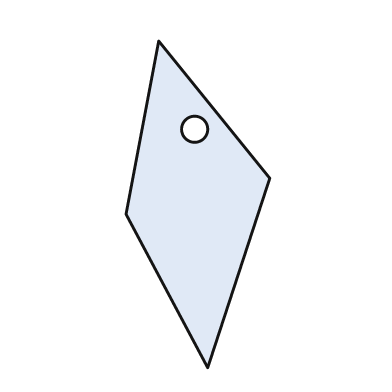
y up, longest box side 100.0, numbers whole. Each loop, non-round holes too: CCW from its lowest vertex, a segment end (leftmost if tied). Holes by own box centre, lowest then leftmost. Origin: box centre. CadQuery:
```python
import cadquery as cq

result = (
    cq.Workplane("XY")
    .moveTo(3.0, -50.0)
    .lineTo(22.0, 8.0)
    .lineTo(-12.0, 50.0)
    .lineTo(-22.0, -3.0)
    .close()
    .moveTo(-1.0, 23.0)
    .circle(4.0)
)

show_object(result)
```